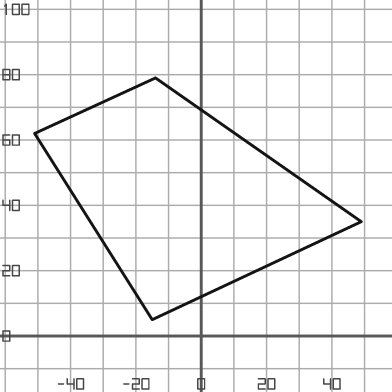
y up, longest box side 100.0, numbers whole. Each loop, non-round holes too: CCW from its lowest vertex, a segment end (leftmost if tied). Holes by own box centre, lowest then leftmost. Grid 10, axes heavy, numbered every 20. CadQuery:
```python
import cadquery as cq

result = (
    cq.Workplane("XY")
    .moveTo(-15.0, 5.0)
    .lineTo(49.0, 35.0)
    .lineTo(-14.0, 79.0)
    .lineTo(-51.0, 62.0)
    .close()
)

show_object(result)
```